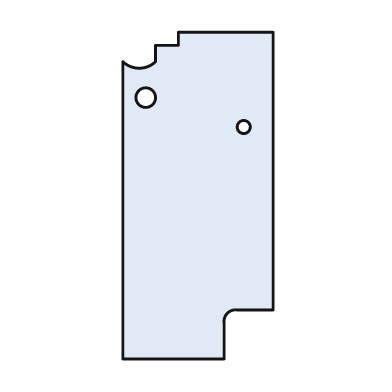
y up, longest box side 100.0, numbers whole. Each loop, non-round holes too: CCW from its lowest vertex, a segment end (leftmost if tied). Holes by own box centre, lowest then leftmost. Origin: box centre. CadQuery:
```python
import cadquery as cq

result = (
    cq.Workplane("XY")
    .moveTo(-23.0, -50.0)
    .lineTo(8.0, -50.0)
    .lineTo(8.0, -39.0)
    .threePointArc((9.0, -36.0), (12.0, -35.0))
    .lineTo(23.0, -35.0)
    .lineTo(23.0, 50.0)
    .lineTo(-6.0, 50.0)
    .lineTo(-6.0, 46.0)
    .lineTo(-13.0, 46.0)
    .lineTo(-13.0, 41.0)
    .threePointArc((-18.0, 39.0), (-23.0, 41.0))
    .close()
    .moveTo(14.0, 21.0)
    .circle(2.0)
    .moveTo(-16.0, 30.0)
    .circle(3.0)
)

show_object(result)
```